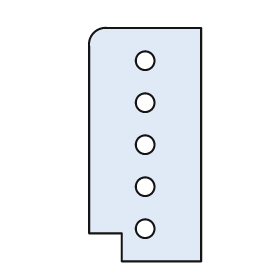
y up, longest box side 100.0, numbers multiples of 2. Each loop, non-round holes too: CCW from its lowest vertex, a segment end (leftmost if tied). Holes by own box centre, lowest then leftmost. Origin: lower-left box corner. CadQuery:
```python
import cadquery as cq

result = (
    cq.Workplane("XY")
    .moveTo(14.0, 0.0)
    .lineTo(48.0, 0.0)
    .lineTo(48.0, 100.0)
    .lineTo(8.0, 100.0)
    .threePointArc((2.0, 98.0), (0.0, 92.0))
    .lineTo(0.0, 12.0)
    .lineTo(14.0, 12.0)
    .close()
    .moveTo(24.0, 14.0)
    .circle(4.0)
    .moveTo(24.0, 32.0)
    .circle(4.0)
    .moveTo(24.0, 50.0)
    .circle(4.0)
    .moveTo(24.0, 68.0)
    .circle(4.0)
    .moveTo(24.0, 86.0)
    .circle(4.0)
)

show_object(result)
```